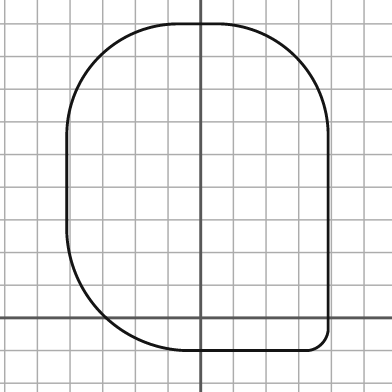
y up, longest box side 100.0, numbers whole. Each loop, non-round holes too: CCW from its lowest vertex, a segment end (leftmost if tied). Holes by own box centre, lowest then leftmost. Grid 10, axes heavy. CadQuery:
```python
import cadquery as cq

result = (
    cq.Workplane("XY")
    .moveTo(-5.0, -10.0)
    .lineTo(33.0, -10.0)
    .threePointArc((37.0, -8.0), (39.0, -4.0))
    .lineTo(39.0, 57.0)
    .threePointArc((29.0, 80.0), (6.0, 90.0))
    .lineTo(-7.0, 90.0)
    .threePointArc((-31.0, 80.0), (-41.0, 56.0))
    .lineTo(-41.0, 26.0)
    .threePointArc((-30.0, 1.0), (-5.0, -10.0))
    .close()
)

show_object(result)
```